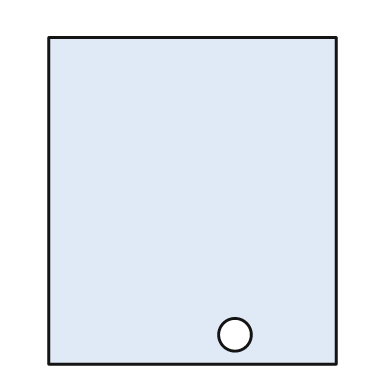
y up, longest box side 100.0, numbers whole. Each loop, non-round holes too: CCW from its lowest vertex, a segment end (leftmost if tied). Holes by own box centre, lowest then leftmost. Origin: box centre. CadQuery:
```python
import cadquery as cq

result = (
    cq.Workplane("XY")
    .moveTo(-44.0, -50.0)
    .lineTo(44.0, -50.0)
    .lineTo(44.0, 50.0)
    .lineTo(-44.0, 50.0)
    .close()
    .moveTo(13.0, -41.0)
    .circle(5.0)
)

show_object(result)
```